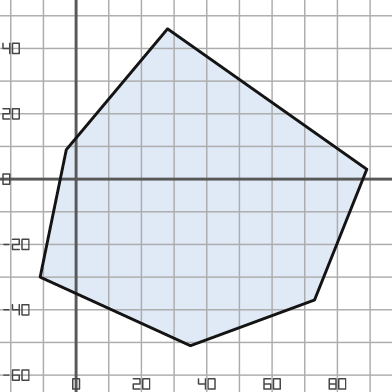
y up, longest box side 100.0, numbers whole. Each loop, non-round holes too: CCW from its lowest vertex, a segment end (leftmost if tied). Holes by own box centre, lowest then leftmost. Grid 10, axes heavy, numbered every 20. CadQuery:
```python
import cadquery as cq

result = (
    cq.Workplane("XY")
    .moveTo(35.0, -51.0)
    .lineTo(73.0, -37.0)
    .lineTo(89.0, 3.0)
    .lineTo(28.0, 46.0)
    .lineTo(-3.0, 9.0)
    .lineTo(-11.0, -30.0)
    .close()
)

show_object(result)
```